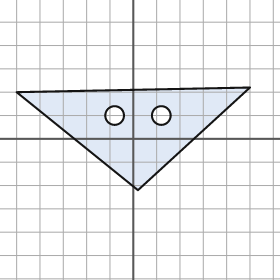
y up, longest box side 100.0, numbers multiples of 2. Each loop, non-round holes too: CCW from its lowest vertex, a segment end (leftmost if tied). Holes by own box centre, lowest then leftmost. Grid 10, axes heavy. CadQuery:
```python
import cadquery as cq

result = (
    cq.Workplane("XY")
    .moveTo(2.0, -22.0)
    .lineTo(50.0, 22.0)
    .lineTo(-50.0, 20.0)
    .close()
    .moveTo(-8.0, 10.0)
    .circle(4.0)
    .moveTo(12.0, 10.0)
    .circle(4.0)
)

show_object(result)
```